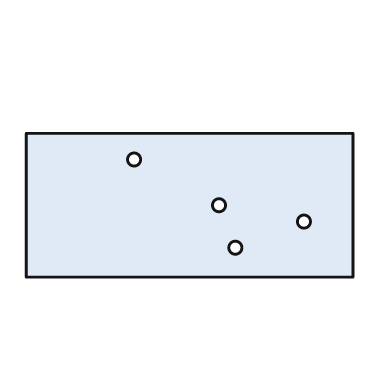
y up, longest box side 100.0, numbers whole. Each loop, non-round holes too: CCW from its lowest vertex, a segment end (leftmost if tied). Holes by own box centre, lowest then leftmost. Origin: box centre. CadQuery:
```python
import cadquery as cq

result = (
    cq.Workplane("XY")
    .moveTo(-50.0, -22.0)
    .lineTo(50.0, -22.0)
    .lineTo(50.0, 22.0)
    .lineTo(-50.0, 22.0)
    .close()
    .moveTo(14.0, -13.0)
    .circle(2.0)
    .moveTo(35.0, -5.0)
    .circle(2.0)
    .moveTo(9.0, 0.0)
    .circle(2.0)
    .moveTo(-17.0, 14.0)
    .circle(2.0)
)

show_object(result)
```